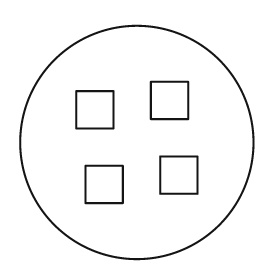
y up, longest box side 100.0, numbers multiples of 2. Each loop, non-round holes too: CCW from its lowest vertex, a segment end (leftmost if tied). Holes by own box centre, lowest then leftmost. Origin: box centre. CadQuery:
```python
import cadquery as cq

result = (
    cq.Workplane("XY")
    .moveTo(0.0, 0.0)
    .circle(50.0)
    .moveTo(-22.0, -26.0)
    .lineTo(-6.0, -26.0)
    .lineTo(-6.0, -10.0)
    .lineTo(-22.0, -10.0)
    .close()
    .moveTo(10.0, -22.0)
    .lineTo(26.0, -22.0)
    .lineTo(26.0, -6.0)
    .lineTo(10.0, -6.0)
    .close()
    .moveTo(-26.0, 6.0)
    .lineTo(-10.0, 6.0)
    .lineTo(-10.0, 22.0)
    .lineTo(-26.0, 22.0)
    .close()
    .moveTo(6.0, 10.0)
    .lineTo(22.0, 10.0)
    .lineTo(22.0, 26.0)
    .lineTo(6.0, 26.0)
    .close()
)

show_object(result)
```